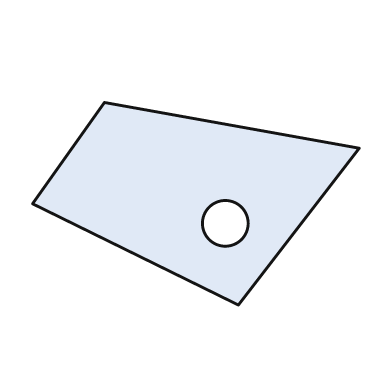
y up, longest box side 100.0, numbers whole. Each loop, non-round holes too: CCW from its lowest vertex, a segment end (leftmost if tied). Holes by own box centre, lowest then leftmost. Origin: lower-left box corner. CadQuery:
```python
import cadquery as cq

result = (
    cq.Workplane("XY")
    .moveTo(63.0, 0.0)
    .lineTo(100.0, 48.0)
    .lineTo(22.0, 62.0)
    .lineTo(0.0, 31.0)
    .close()
    .moveTo(59.0, 25.0)
    .circle(7.0)
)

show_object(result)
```